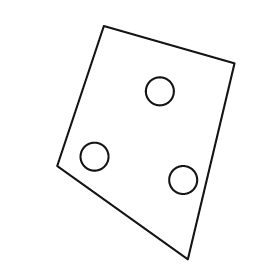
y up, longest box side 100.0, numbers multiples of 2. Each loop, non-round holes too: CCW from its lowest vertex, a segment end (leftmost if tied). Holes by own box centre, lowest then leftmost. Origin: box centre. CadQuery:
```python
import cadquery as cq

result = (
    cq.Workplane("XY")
    .moveTo(18.0, -50.0)
    .lineTo(38.0, 34.0)
    .lineTo(-18.0, 50.0)
    .lineTo(-38.0, -10.0)
    .close()
    .moveTo(16.0, -16.0)
    .circle(6.0)
    .moveTo(-22.0, -6.0)
    .circle(6.0)
    .moveTo(6.0, 22.0)
    .circle(6.0)
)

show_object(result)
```